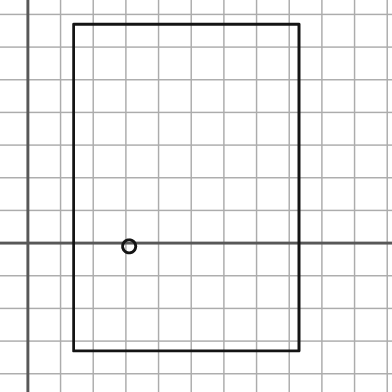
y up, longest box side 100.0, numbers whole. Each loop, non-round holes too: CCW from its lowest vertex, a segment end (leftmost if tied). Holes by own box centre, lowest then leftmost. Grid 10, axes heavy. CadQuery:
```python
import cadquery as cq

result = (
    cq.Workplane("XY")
    .moveTo(14.0, -33.0)
    .lineTo(83.0, -33.0)
    .lineTo(83.0, 67.0)
    .lineTo(14.0, 67.0)
    .close()
    .moveTo(31.0, -1.0)
    .circle(2.0)
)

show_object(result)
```